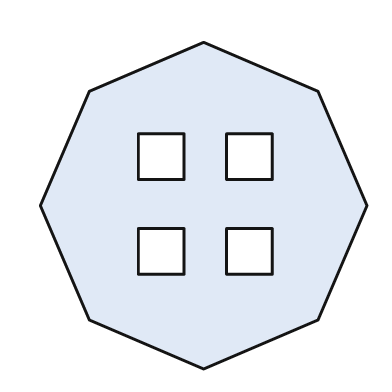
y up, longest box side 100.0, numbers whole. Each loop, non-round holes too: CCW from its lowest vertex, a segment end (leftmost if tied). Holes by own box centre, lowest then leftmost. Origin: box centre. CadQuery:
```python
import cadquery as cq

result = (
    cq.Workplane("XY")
    .moveTo(0.0, -50.0)
    .lineTo(35.0, -35.0)
    .lineTo(50.0, 0.0)
    .lineTo(35.0, 35.0)
    .lineTo(0.0, 50.0)
    .lineTo(-35.0, 35.0)
    .lineTo(-50.0, 0.0)
    .lineTo(-35.0, -35.0)
    .close()
    .moveTo(-20.0, -21.0)
    .lineTo(-6.0, -21.0)
    .lineTo(-6.0, -7.0)
    .lineTo(-20.0, -7.0)
    .close()
    .moveTo(7.0, -21.0)
    .lineTo(21.0, -21.0)
    .lineTo(21.0, -7.0)
    .lineTo(7.0, -7.0)
    .close()
    .moveTo(-20.0, 8.0)
    .lineTo(-6.0, 8.0)
    .lineTo(-6.0, 22.0)
    .lineTo(-20.0, 22.0)
    .close()
    .moveTo(7.0, 8.0)
    .lineTo(21.0, 8.0)
    .lineTo(21.0, 22.0)
    .lineTo(7.0, 22.0)
    .close()
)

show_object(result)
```